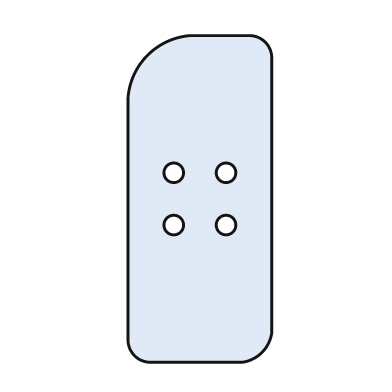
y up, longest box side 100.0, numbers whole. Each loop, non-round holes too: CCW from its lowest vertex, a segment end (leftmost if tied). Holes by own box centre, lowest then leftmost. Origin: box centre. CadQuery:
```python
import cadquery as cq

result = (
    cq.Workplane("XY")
    .moveTo(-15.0, -50.0)
    .lineTo(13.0, -50.0)
    .threePointArc((19.0, -47.0), (22.0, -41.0))
    .lineTo(22.0, 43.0)
    .threePointArc((20.0, 48.0), (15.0, 50.0))
    .lineTo(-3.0, 50.0)
    .threePointArc((-16.0, 44.0), (-22.0, 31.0))
    .lineTo(-22.0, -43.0)
    .threePointArc((-20.0, -48.0), (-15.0, -50.0))
    .close()
    .moveTo(-8.0, -8.0)
    .circle(3.0)
    .moveTo(8.0, -8.0)
    .circle(3.0)
    .moveTo(-8.0, 8.0)
    .circle(3.0)
    .moveTo(8.0, 8.0)
    .circle(3.0)
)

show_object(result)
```